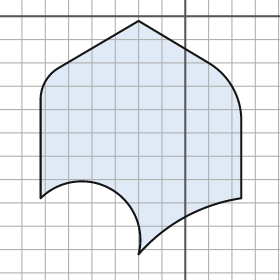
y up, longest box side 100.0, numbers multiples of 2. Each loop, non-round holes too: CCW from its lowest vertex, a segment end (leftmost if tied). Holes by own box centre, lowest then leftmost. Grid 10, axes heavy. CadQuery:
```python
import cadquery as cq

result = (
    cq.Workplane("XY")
    .moveTo(-20.0, -102.0)
    .threePointArc((0.0, -86.0), (24.0, -78.0))
    .lineTo(24.0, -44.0)
    .threePointArc((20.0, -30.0), (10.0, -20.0))
    .lineTo(-20.0, -2.0)
    .lineTo(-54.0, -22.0)
    .threePointArc((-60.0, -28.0), (-62.0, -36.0))
    .lineTo(-62.0, -78.0)
    .threePointArc((-32.0, -74.0), (-20.0, -102.0))
    .close()
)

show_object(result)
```